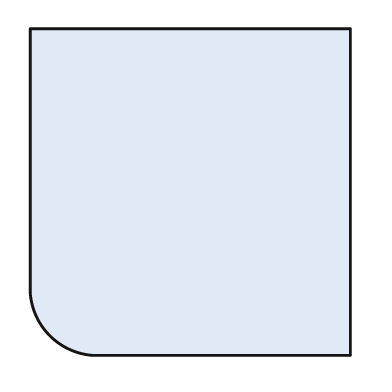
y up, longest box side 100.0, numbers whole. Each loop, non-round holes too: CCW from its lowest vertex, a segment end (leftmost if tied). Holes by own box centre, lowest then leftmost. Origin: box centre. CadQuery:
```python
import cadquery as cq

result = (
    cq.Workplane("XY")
    .moveTo(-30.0, -50.0)
    .lineTo(49.0, -50.0)
    .lineTo(49.0, 50.0)
    .lineTo(-49.0, 50.0)
    .lineTo(-49.0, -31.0)
    .threePointArc((-43.0, -44.0), (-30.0, -50.0))
    .close()
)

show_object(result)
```